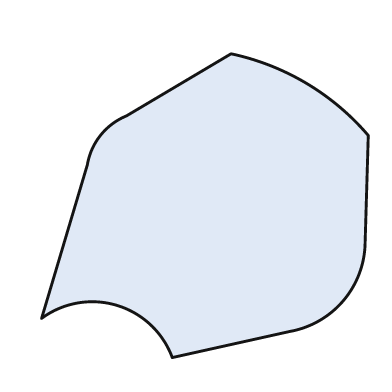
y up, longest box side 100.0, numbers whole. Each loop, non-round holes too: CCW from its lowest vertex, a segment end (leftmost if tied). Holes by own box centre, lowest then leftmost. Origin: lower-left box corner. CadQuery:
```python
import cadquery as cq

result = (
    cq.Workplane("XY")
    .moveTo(40.0, 0.0)
    .lineTo(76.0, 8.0)
    .threePointArc((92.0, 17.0), (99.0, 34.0))
    .lineTo(100.0, 68.0)
    .threePointArc((81.0, 84.0), (58.0, 93.0))
    .lineTo(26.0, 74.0)
    .threePointArc((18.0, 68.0), (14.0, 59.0))
    .lineTo(0.0, 12.0)
    .threePointArc((23.0, 16.0), (40.0, 0.0))
    .close()
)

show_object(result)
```